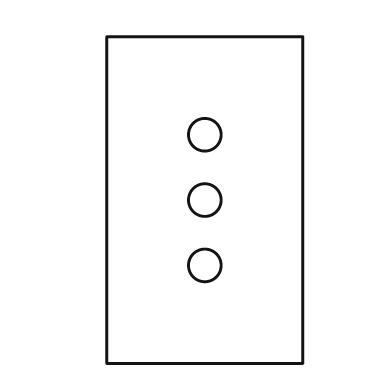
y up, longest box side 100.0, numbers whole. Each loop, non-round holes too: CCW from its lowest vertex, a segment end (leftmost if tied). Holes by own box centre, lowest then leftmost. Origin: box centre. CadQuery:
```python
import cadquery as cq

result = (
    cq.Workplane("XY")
    .moveTo(-30.0, -50.0)
    .lineTo(30.0, -50.0)
    .lineTo(30.0, 50.0)
    .lineTo(-30.0, 50.0)
    .close()
    .moveTo(0.0, -20.0)
    .circle(5.0)
    .moveTo(0.0, 0.0)
    .circle(5.0)
    .moveTo(0.0, 20.0)
    .circle(5.0)
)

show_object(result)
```